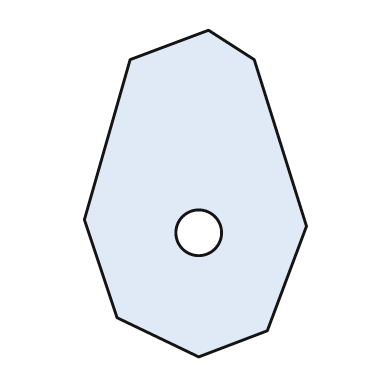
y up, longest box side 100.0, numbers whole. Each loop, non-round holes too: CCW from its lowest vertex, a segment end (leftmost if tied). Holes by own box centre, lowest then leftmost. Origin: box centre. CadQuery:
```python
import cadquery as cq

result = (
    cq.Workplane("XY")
    .moveTo(1.0, -50.0)
    .lineTo(22.0, -42.0)
    .lineTo(34.0, -10.0)
    .lineTo(18.0, 41.0)
    .lineTo(4.0, 50.0)
    .lineTo(-20.0, 41.0)
    .lineTo(-34.0, -8.0)
    .lineTo(-24.0, -38.0)
    .close()
    .moveTo(1.0, -12.0)
    .circle(7.0)
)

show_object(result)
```